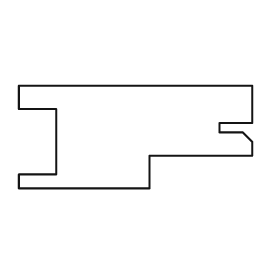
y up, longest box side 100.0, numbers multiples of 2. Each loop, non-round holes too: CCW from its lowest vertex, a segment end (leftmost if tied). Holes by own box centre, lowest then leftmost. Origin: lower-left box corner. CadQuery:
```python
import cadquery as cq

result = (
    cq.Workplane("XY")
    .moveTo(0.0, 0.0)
    .lineTo(56.0, 0.0)
    .lineTo(56.0, 14.0)
    .lineTo(100.0, 14.0)
    .lineTo(100.0, 20.0)
    .lineTo(96.0, 24.0)
    .lineTo(86.0, 24.0)
    .lineTo(86.0, 28.0)
    .lineTo(100.0, 28.0)
    .lineTo(100.0, 44.0)
    .lineTo(0.0, 44.0)
    .lineTo(0.0, 34.0)
    .lineTo(16.0, 34.0)
    .lineTo(16.0, 6.0)
    .lineTo(0.0, 6.0)
    .close()
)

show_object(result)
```